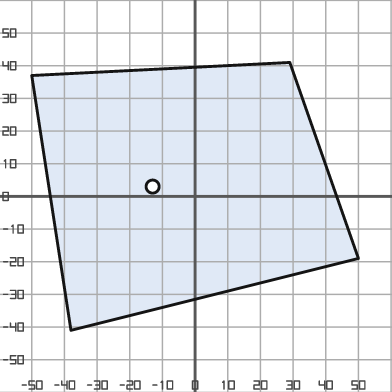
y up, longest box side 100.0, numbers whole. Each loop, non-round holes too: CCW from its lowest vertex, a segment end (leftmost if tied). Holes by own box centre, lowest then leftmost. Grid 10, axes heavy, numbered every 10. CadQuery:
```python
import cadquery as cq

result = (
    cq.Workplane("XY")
    .moveTo(-38.0, -41.0)
    .lineTo(50.0, -19.0)
    .lineTo(29.0, 41.0)
    .lineTo(-50.0, 37.0)
    .close()
    .moveTo(-13.0, 3.0)
    .circle(2.0)
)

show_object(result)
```